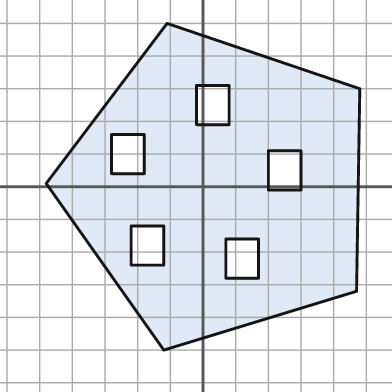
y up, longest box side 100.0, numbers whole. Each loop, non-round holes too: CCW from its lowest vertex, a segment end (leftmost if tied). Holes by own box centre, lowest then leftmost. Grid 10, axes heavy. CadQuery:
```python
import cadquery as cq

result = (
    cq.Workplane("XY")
    .moveTo(-12.0, -50.0)
    .lineTo(47.0, -32.0)
    .lineTo(48.0, 30.0)
    .lineTo(-11.0, 50.0)
    .lineTo(-48.0, 1.0)
    .close()
    .moveTo(7.0, -28.0)
    .lineTo(17.0, -28.0)
    .lineTo(17.0, -16.0)
    .lineTo(7.0, -16.0)
    .close()
    .moveTo(-22.0, -24.0)
    .lineTo(-12.0, -24.0)
    .lineTo(-12.0, -12.0)
    .lineTo(-22.0, -12.0)
    .close()
    .moveTo(20.0, -1.0)
    .lineTo(30.0, -1.0)
    .lineTo(30.0, 11.0)
    .lineTo(20.0, 11.0)
    .close()
    .moveTo(-28.0, 4.0)
    .lineTo(-18.0, 4.0)
    .lineTo(-18.0, 16.0)
    .lineTo(-28.0, 16.0)
    .close()
    .moveTo(-2.0, 19.0)
    .lineTo(8.0, 19.0)
    .lineTo(8.0, 31.0)
    .lineTo(-2.0, 31.0)
    .close()
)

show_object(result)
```